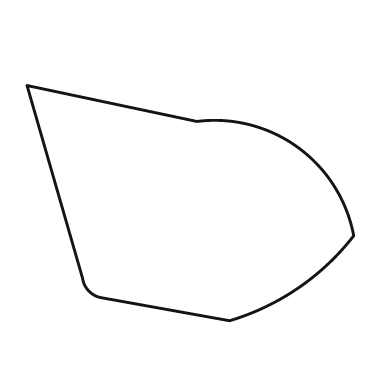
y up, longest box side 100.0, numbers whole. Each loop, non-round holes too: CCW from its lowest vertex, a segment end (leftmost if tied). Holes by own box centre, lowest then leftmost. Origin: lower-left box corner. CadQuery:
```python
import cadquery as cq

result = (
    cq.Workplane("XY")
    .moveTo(62.0, 0.0)
    .threePointArc((83.0, 10.0), (100.0, 26.0))
    .threePointArc((83.0, 53.0), (52.0, 61.0))
    .lineTo(0.0, 72.0)
    .lineTo(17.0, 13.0)
    .threePointArc((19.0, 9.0), (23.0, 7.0))
    .close()
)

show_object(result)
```